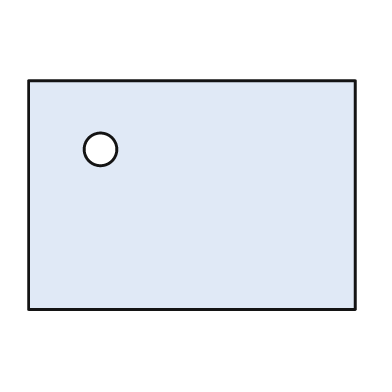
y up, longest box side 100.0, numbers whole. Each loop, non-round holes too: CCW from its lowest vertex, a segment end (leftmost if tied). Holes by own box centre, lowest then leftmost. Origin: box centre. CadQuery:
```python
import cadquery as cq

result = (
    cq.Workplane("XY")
    .moveTo(-50.0, -35.0)
    .lineTo(50.0, -35.0)
    .lineTo(50.0, 35.0)
    .lineTo(-50.0, 35.0)
    .close()
    .moveTo(-28.0, 14.0)
    .circle(5.0)
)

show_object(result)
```